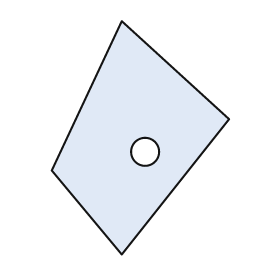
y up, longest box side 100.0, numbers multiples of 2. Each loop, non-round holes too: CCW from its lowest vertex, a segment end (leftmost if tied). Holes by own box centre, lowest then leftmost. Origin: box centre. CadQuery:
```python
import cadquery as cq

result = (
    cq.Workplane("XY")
    .moveTo(-8.0, -50.0)
    .lineTo(38.0, 8.0)
    .lineTo(-8.0, 50.0)
    .lineTo(-38.0, -14.0)
    .close()
    .moveTo(2.0, -6.0)
    .circle(6.0)
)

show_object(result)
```